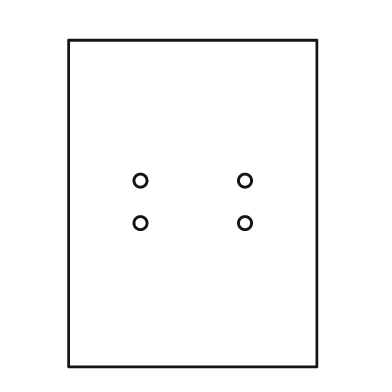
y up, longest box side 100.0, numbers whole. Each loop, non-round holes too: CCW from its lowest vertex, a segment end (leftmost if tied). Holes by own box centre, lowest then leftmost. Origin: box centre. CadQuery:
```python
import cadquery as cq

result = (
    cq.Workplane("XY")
    .moveTo(-38.0, -50.0)
    .lineTo(38.0, -50.0)
    .lineTo(38.0, 50.0)
    .lineTo(-38.0, 50.0)
    .close()
    .moveTo(-16.0, -6.0)
    .circle(2.0)
    .moveTo(16.0, -6.0)
    .circle(2.0)
    .moveTo(-16.0, 7.0)
    .circle(2.0)
    .moveTo(16.0, 7.0)
    .circle(2.0)
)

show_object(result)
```